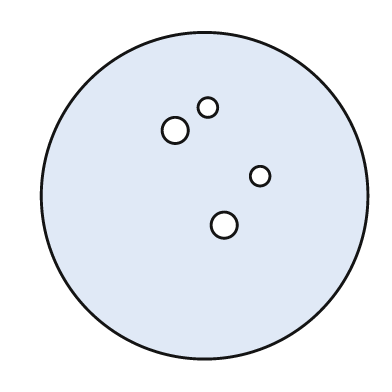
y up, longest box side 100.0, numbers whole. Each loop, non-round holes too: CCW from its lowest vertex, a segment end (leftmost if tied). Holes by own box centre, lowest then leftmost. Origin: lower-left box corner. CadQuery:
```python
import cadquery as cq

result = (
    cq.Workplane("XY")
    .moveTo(50.0, 50.0)
    .circle(50.0)
    .moveTo(56.0, 41.0)
    .circle(4.0)
    .moveTo(67.0, 56.0)
    .circle(3.0)
    .moveTo(41.0, 70.0)
    .circle(4.0)
    .moveTo(51.0, 77.0)
    .circle(3.0)
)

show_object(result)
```